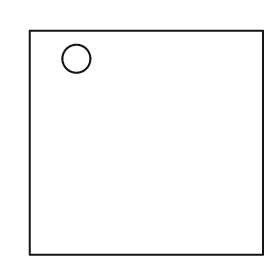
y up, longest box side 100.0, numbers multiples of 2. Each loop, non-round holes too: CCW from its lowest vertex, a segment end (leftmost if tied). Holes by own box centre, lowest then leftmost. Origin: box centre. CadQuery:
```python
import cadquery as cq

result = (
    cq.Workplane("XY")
    .moveTo(-50.0, -48.0)
    .lineTo(50.0, -48.0)
    .lineTo(50.0, 48.0)
    .lineTo(-50.0, 48.0)
    .close()
    .moveTo(-30.0, 36.0)
    .circle(6.0)
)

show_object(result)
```